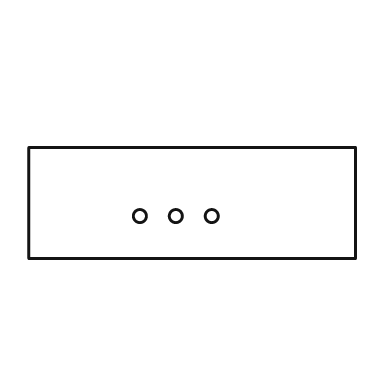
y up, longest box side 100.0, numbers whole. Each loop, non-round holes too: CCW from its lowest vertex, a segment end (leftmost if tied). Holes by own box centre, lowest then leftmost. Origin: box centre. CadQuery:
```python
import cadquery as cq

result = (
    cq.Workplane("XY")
    .moveTo(-50.0, -17.0)
    .lineTo(50.0, -17.0)
    .lineTo(50.0, 17.0)
    .lineTo(-50.0, 17.0)
    .close()
    .moveTo(-16.0, -4.0)
    .circle(2.0)
    .moveTo(-5.0, -4.0)
    .circle(2.0)
    .moveTo(6.0, -4.0)
    .circle(2.0)
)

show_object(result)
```